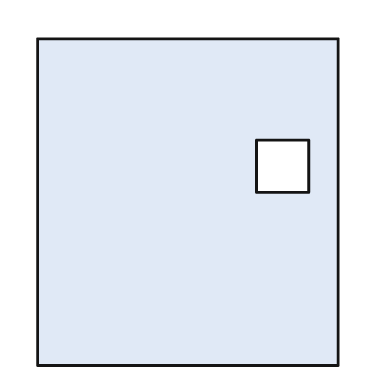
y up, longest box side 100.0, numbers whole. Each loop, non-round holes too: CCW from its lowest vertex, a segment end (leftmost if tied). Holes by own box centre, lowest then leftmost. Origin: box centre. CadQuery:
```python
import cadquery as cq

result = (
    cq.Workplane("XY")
    .moveTo(-46.0, -50.0)
    .lineTo(46.0, -50.0)
    .lineTo(46.0, 50.0)
    .lineTo(-46.0, 50.0)
    .close()
    .moveTo(21.0, 3.0)
    .lineTo(37.0, 3.0)
    .lineTo(37.0, 19.0)
    .lineTo(21.0, 19.0)
    .close()
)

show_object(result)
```